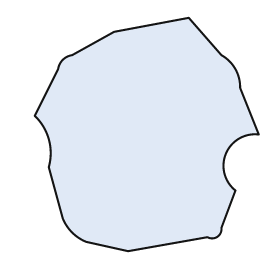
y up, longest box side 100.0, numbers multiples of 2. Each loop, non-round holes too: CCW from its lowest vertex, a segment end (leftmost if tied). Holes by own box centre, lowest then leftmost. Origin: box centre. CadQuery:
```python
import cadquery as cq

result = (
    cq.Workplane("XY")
    .moveTo(-8.0, -50.0)
    .lineTo(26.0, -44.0)
    .threePointArc((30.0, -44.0), (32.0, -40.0))
    .lineTo(38.0, -24.0)
    .threePointArc((34.0, -8.0), (48.0, 0.0))
    .lineTo(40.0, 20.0)
    .threePointArc((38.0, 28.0), (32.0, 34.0))
    .lineTo(18.0, 50.0)
    .lineTo(-14.0, 44.0)
    .lineTo(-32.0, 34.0)
    .threePointArc((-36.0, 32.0), (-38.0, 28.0))
    .lineTo(-48.0, 8.0)
    .threePointArc((-42.0, -2.0), (-42.0, -14.0))
    .lineTo(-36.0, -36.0)
    .threePointArc((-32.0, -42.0), (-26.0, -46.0))
    .close()
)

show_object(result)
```